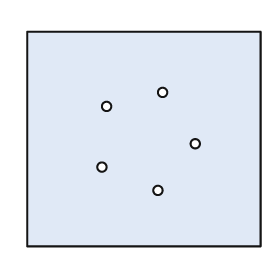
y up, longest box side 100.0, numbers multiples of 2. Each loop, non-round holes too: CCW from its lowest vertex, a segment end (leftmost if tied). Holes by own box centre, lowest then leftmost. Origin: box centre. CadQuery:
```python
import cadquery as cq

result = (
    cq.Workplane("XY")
    .moveTo(-50.0, -46.0)
    .lineTo(50.0, -46.0)
    .lineTo(50.0, 46.0)
    .lineTo(-50.0, 46.0)
    .close()
    .moveTo(6.0, -22.0)
    .circle(2.0)
    .moveTo(-18.0, -12.0)
    .circle(2.0)
    .moveTo(22.0, -2.0)
    .circle(2.0)
    .moveTo(-16.0, 14.0)
    .circle(2.0)
    .moveTo(8.0, 20.0)
    .circle(2.0)
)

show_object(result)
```